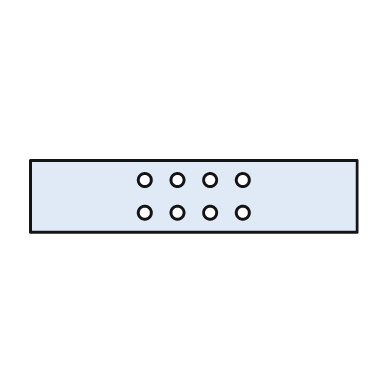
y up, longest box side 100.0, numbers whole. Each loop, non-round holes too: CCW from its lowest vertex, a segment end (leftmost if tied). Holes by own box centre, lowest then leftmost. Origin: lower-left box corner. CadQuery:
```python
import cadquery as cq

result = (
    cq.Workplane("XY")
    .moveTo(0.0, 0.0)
    .lineTo(100.0, 0.0)
    .lineTo(100.0, 22.0)
    .lineTo(0.0, 22.0)
    .close()
    .moveTo(35.0, 6.0)
    .circle(2.0)
    .moveTo(45.0, 6.0)
    .circle(2.0)
    .moveTo(55.0, 6.0)
    .circle(2.0)
    .moveTo(65.0, 6.0)
    .circle(2.0)
    .moveTo(35.0, 16.0)
    .circle(2.0)
    .moveTo(45.0, 16.0)
    .circle(2.0)
    .moveTo(55.0, 16.0)
    .circle(2.0)
    .moveTo(65.0, 16.0)
    .circle(2.0)
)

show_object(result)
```